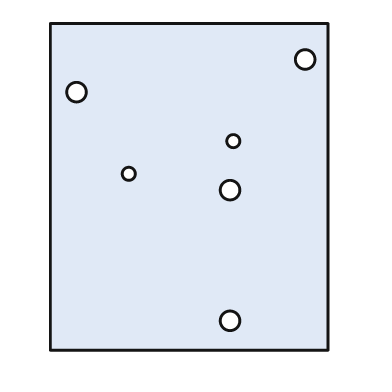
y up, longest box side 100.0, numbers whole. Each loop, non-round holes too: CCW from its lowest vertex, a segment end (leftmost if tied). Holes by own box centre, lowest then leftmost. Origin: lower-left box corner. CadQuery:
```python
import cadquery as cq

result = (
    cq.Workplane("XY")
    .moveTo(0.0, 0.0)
    .lineTo(85.0, 0.0)
    .lineTo(85.0, 100.0)
    .lineTo(0.0, 100.0)
    .close()
    .moveTo(55.0, 9.0)
    .circle(3.0)
    .moveTo(55.0, 49.0)
    .circle(3.0)
    .moveTo(24.0, 54.0)
    .circle(2.0)
    .moveTo(56.0, 64.0)
    .circle(2.0)
    .moveTo(8.0, 79.0)
    .circle(3.0)
    .moveTo(78.0, 89.0)
    .circle(3.0)
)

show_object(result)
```